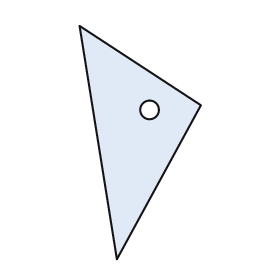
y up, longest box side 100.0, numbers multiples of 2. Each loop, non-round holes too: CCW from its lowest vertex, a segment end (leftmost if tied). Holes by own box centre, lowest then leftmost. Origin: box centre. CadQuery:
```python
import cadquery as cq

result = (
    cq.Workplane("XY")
    .moveTo(-10.0, -50.0)
    .lineTo(26.0, 16.0)
    .lineTo(-26.0, 50.0)
    .close()
    .moveTo(4.0, 14.0)
    .circle(4.0)
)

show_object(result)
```